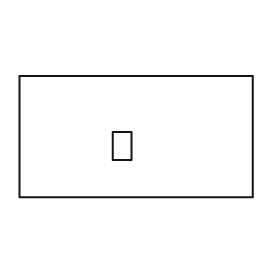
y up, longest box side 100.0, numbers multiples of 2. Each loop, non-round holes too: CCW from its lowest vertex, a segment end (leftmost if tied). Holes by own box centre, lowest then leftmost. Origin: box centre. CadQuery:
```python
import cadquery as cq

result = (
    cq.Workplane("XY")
    .moveTo(-50.0, -26.0)
    .lineTo(50.0, -26.0)
    .lineTo(50.0, 26.0)
    .lineTo(-50.0, 26.0)
    .close()
    .moveTo(-10.0, -10.0)
    .lineTo(-2.0, -10.0)
    .lineTo(-2.0, 2.0)
    .lineTo(-10.0, 2.0)
    .close()
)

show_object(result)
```